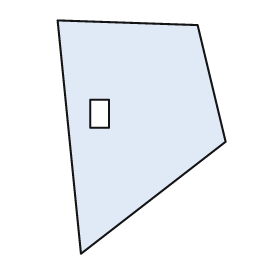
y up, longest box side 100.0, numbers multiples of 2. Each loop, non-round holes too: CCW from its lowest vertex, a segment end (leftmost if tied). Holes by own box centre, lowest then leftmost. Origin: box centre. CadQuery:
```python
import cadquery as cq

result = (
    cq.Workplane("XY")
    .moveTo(-26.0, -50.0)
    .lineTo(36.0, -2.0)
    .lineTo(24.0, 48.0)
    .lineTo(-36.0, 50.0)
    .close()
    .moveTo(-22.0, 4.0)
    .lineTo(-14.0, 4.0)
    .lineTo(-14.0, 16.0)
    .lineTo(-22.0, 16.0)
    .close()
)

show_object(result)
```